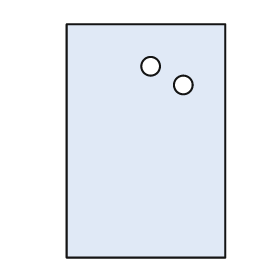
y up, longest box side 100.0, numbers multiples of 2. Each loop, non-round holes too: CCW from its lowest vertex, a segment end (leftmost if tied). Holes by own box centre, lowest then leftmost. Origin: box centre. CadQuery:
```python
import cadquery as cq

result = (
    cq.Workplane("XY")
    .moveTo(-34.0, -50.0)
    .lineTo(34.0, -50.0)
    .lineTo(34.0, 50.0)
    .lineTo(-34.0, 50.0)
    .close()
    .moveTo(16.0, 24.0)
    .circle(4.0)
    .moveTo(2.0, 32.0)
    .circle(4.0)
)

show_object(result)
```